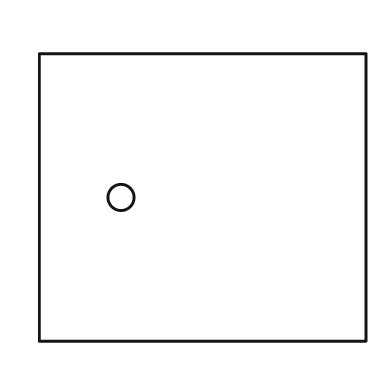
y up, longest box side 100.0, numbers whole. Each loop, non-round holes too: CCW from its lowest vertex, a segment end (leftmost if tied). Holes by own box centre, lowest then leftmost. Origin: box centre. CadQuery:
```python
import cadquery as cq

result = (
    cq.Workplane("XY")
    .moveTo(-50.0, -44.0)
    .lineTo(50.0, -44.0)
    .lineTo(50.0, 44.0)
    .lineTo(-50.0, 44.0)
    .close()
    .moveTo(-25.0, 0.0)
    .circle(4.0)
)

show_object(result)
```